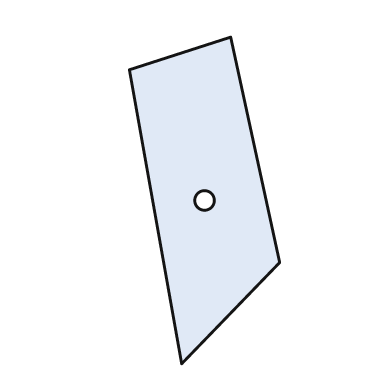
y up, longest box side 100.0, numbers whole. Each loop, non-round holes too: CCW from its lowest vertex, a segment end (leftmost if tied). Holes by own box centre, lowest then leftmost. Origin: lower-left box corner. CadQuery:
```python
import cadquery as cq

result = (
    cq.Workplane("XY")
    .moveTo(16.0, 0.0)
    .lineTo(46.0, 31.0)
    .lineTo(31.0, 100.0)
    .lineTo(0.0, 90.0)
    .close()
    .moveTo(23.0, 50.0)
    .circle(3.0)
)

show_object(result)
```